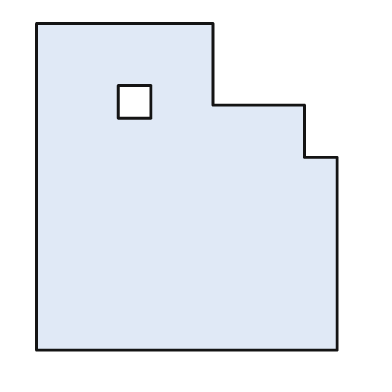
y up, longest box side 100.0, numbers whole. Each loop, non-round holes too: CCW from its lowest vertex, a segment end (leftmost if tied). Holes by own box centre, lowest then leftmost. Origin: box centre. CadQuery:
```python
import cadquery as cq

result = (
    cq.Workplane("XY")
    .moveTo(-46.0, -50.0)
    .lineTo(46.0, -50.0)
    .lineTo(46.0, 9.0)
    .lineTo(36.0, 9.0)
    .lineTo(36.0, 25.0)
    .lineTo(8.0, 25.0)
    .lineTo(8.0, 50.0)
    .lineTo(-46.0, 50.0)
    .close()
    .moveTo(-21.0, 21.0)
    .lineTo(-11.0, 21.0)
    .lineTo(-11.0, 31.0)
    .lineTo(-21.0, 31.0)
    .close()
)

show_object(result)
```